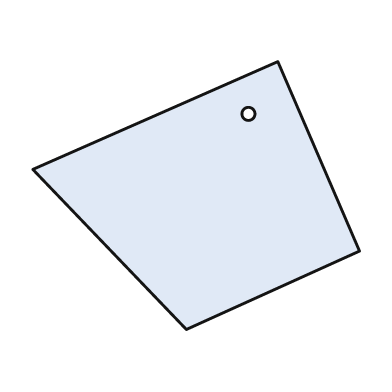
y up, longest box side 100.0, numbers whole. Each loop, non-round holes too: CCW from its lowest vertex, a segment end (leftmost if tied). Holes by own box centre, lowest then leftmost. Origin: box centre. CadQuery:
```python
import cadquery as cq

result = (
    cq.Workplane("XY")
    .moveTo(-3.0, -41.0)
    .lineTo(50.0, -17.0)
    .lineTo(25.0, 41.0)
    .lineTo(-50.0, 8.0)
    .close()
    .moveTo(16.0, 25.0)
    .circle(2.0)
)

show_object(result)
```